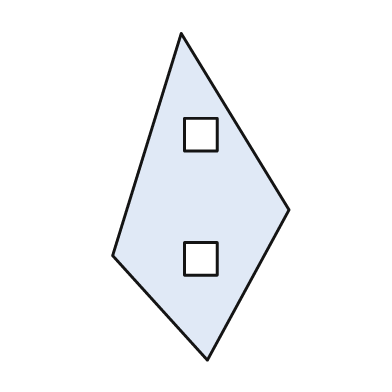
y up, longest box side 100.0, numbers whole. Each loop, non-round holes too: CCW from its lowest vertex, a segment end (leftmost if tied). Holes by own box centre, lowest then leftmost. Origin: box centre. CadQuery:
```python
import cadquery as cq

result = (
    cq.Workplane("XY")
    .moveTo(2.0, -50.0)
    .lineTo(27.0, -4.0)
    .lineTo(-6.0, 50.0)
    .lineTo(-27.0, -18.0)
    .close()
    .moveTo(-5.0, -24.0)
    .lineTo(5.0, -24.0)
    .lineTo(5.0, -14.0)
    .lineTo(-5.0, -14.0)
    .close()
    .moveTo(-5.0, 14.0)
    .lineTo(5.0, 14.0)
    .lineTo(5.0, 24.0)
    .lineTo(-5.0, 24.0)
    .close()
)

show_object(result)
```